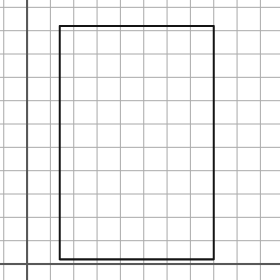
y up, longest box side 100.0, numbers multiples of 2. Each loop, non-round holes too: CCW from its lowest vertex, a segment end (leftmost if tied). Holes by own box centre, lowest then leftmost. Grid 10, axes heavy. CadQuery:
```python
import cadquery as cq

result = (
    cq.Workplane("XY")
    .moveTo(14.0, 2.0)
    .lineTo(80.0, 2.0)
    .lineTo(80.0, 102.0)
    .lineTo(14.0, 102.0)
    .close()
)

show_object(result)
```